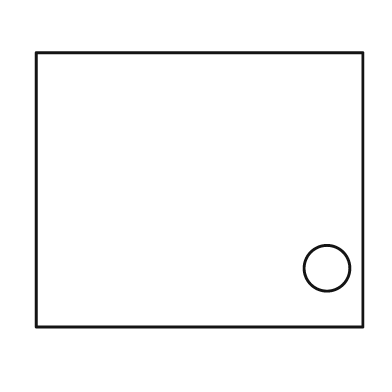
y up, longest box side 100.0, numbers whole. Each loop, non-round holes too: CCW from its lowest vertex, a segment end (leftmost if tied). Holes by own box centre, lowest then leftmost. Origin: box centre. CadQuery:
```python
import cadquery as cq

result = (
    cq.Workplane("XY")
    .moveTo(-50.0, -42.0)
    .lineTo(50.0, -42.0)
    .lineTo(50.0, 42.0)
    .lineTo(-50.0, 42.0)
    .close()
    .moveTo(39.0, -24.0)
    .circle(7.0)
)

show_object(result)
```